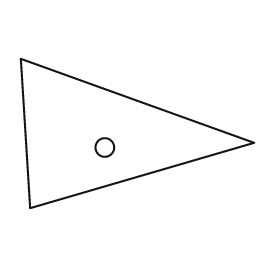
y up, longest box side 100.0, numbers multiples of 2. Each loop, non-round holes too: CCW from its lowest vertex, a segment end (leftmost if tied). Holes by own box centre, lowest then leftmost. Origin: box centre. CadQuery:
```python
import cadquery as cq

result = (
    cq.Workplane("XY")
    .moveTo(-46.0, -32.0)
    .lineTo(50.0, -4.0)
    .lineTo(-50.0, 32.0)
    .close()
    .moveTo(-14.0, -6.0)
    .circle(4.0)
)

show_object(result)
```